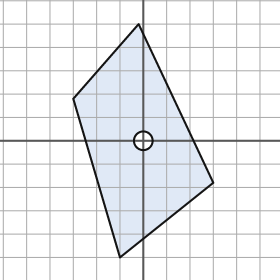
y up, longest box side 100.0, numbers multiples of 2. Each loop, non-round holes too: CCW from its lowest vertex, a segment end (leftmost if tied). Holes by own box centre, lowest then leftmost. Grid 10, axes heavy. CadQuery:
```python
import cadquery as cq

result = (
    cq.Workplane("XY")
    .moveTo(-10.0, -50.0)
    .lineTo(30.0, -18.0)
    .lineTo(-2.0, 50.0)
    .lineTo(-30.0, 18.0)
    .close()
    .moveTo(0.0, 0.0)
    .circle(4.0)
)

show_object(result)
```